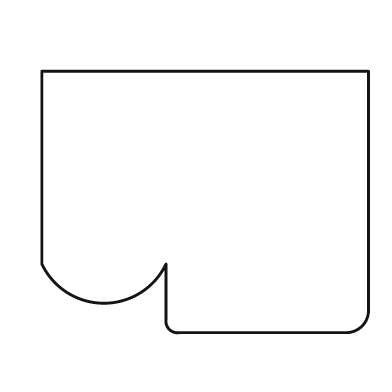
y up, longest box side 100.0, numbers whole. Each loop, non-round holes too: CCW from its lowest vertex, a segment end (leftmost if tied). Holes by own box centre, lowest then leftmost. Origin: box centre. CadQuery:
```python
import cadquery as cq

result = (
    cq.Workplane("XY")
    .moveTo(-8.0, -40.0)
    .lineTo(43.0, -40.0)
    .threePointArc((48.0, -38.0), (50.0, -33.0))
    .lineTo(50.0, 40.0)
    .lineTo(-50.0, 40.0)
    .lineTo(-50.0, -19.0)
    .threePointArc((-31.0, -31.0), (-12.0, -19.0))
    .lineTo(-12.0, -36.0)
    .threePointArc((-11.0, -39.0), (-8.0, -40.0))
    .close()
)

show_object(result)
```